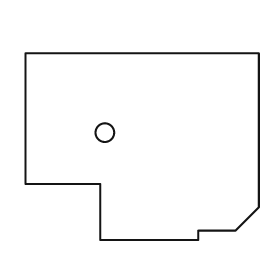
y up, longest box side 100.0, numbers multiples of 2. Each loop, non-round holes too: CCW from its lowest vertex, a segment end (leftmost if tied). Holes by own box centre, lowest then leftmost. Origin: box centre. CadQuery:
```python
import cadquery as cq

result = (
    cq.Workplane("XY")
    .moveTo(-18.0, -40.0)
    .lineTo(24.0, -40.0)
    .lineTo(24.0, -36.0)
    .lineTo(40.0, -36.0)
    .lineTo(50.0, -26.0)
    .lineTo(50.0, 40.0)
    .lineTo(-50.0, 40.0)
    .lineTo(-50.0, -16.0)
    .lineTo(-18.0, -16.0)
    .close()
    .moveTo(-16.0, 6.0)
    .circle(4.0)
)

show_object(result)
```